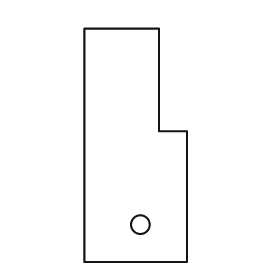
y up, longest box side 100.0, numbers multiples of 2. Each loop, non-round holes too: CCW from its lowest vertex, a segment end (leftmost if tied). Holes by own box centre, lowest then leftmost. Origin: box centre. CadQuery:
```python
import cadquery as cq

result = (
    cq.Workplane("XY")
    .moveTo(-22.0, -50.0)
    .lineTo(22.0, -50.0)
    .lineTo(22.0, 6.0)
    .lineTo(10.0, 6.0)
    .lineTo(10.0, 50.0)
    .lineTo(-22.0, 50.0)
    .close()
    .moveTo(2.0, -34.0)
    .circle(4.0)
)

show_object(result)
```